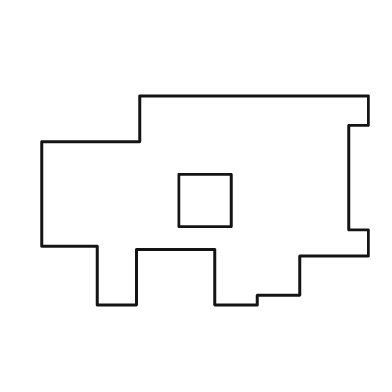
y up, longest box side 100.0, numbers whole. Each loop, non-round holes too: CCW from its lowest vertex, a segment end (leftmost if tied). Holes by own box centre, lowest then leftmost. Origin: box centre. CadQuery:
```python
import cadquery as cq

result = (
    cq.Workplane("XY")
    .moveTo(-33.0, -32.0)
    .lineTo(-21.0, -32.0)
    .lineTo(-21.0, -15.0)
    .lineTo(3.0, -15.0)
    .lineTo(3.0, -32.0)
    .lineTo(16.0, -32.0)
    .lineTo(16.0, -29.0)
    .lineTo(29.0, -29.0)
    .lineTo(29.0, -17.0)
    .lineTo(50.0, -17.0)
    .lineTo(50.0, -9.0)
    .lineTo(44.0, -9.0)
    .lineTo(44.0, 23.0)
    .lineTo(50.0, 23.0)
    .lineTo(50.0, 32.0)
    .lineTo(-20.0, 32.0)
    .lineTo(-20.0, 18.0)
    .lineTo(-50.0, 18.0)
    .lineTo(-50.0, -14.0)
    .lineTo(-33.0, -14.0)
    .close()
    .moveTo(-8.0, -8.0)
    .lineTo(8.0, -8.0)
    .lineTo(8.0, 8.0)
    .lineTo(-8.0, 8.0)
    .close()
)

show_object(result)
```